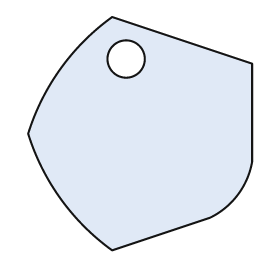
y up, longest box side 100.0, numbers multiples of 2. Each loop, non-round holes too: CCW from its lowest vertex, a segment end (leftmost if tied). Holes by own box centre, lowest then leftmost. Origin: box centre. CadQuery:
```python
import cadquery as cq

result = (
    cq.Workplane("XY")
    .moveTo(-12.0, -50.0)
    .lineTo(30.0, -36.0)
    .threePointArc((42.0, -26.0), (48.0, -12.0))
    .lineTo(48.0, 30.0)
    .lineTo(-12.0, 50.0)
    .threePointArc((-34.0, 28.0), (-48.0, 0.0))
    .threePointArc((-34.0, -28.0), (-12.0, -50.0))
    .close()
    .moveTo(-6.0, 32.0)
    .circle(8.0)
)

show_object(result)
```